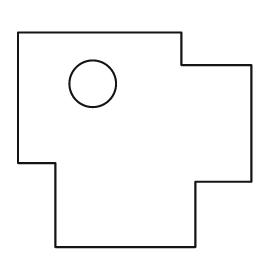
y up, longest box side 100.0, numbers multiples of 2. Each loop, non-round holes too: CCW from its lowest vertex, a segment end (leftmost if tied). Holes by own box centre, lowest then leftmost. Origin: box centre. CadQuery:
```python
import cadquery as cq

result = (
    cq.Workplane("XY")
    .moveTo(-34.0, -46.0)
    .lineTo(26.0, -46.0)
    .lineTo(26.0, -18.0)
    .lineTo(50.0, -18.0)
    .lineTo(50.0, 32.0)
    .lineTo(20.0, 32.0)
    .lineTo(20.0, 46.0)
    .lineTo(-50.0, 46.0)
    .lineTo(-50.0, -10.0)
    .lineTo(-34.0, -10.0)
    .close()
    .moveTo(-18.0, 24.0)
    .circle(10.0)
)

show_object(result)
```